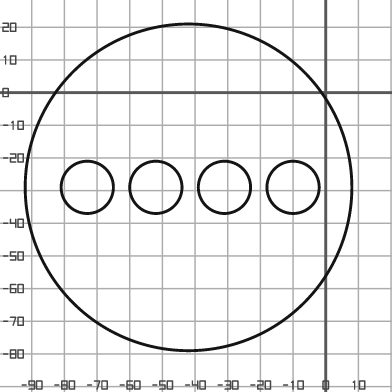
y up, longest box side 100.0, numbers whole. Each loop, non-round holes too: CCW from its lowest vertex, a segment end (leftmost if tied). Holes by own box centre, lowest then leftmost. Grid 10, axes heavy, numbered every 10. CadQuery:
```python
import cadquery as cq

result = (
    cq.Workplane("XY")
    .moveTo(-42.0, -29.0)
    .circle(50.0)
    .moveTo(-73.0, -29.0)
    .circle(8.0)
    .moveTo(-52.0, -29.0)
    .circle(8.0)
    .moveTo(-31.0, -29.0)
    .circle(8.0)
    .moveTo(-10.0, -29.0)
    .circle(8.0)
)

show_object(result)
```